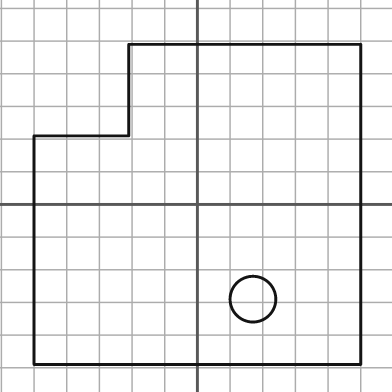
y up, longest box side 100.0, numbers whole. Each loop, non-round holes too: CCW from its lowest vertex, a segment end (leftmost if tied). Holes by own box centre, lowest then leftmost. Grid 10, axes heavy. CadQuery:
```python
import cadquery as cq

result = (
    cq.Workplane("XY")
    .moveTo(-50.0, -49.0)
    .lineTo(50.0, -49.0)
    .lineTo(50.0, 49.0)
    .lineTo(-21.0, 49.0)
    .lineTo(-21.0, 21.0)
    .lineTo(-50.0, 21.0)
    .close()
    .moveTo(17.0, -29.0)
    .circle(7.0)
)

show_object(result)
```